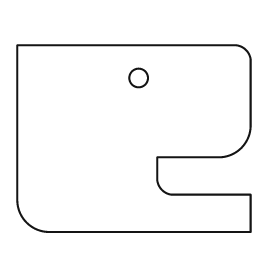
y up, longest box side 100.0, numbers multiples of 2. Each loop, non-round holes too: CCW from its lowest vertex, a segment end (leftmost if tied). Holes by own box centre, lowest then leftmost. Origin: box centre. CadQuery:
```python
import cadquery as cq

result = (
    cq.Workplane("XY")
    .moveTo(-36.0, -40.0)
    .lineTo(50.0, -40.0)
    .lineTo(50.0, -24.0)
    .lineTo(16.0, -24.0)
    .threePointArc((12.0, -22.0), (10.0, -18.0))
    .lineTo(10.0, -8.0)
    .lineTo(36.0, -8.0)
    .threePointArc((46.0, -4.0), (50.0, 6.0))
    .lineTo(50.0, 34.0)
    .threePointArc((48.0, 38.0), (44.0, 40.0))
    .lineTo(-50.0, 40.0)
    .lineTo(-50.0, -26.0)
    .threePointArc((-46.0, -36.0), (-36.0, -40.0))
    .close()
    .moveTo(2.0, 26.0)
    .circle(4.0)
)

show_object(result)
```